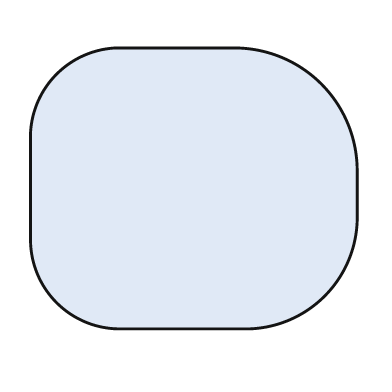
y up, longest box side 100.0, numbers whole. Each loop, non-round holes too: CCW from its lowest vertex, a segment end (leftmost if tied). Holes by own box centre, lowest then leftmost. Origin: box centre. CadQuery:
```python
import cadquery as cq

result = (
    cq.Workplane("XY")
    .moveTo(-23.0, -43.0)
    .lineTo(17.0, -43.0)
    .threePointArc((40.0, -33.0), (50.0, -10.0))
    .lineTo(50.0, 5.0)
    .threePointArc((39.0, 32.0), (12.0, 43.0))
    .lineTo(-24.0, 43.0)
    .threePointArc((-42.0, 35.0), (-50.0, 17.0))
    .lineTo(-50.0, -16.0)
    .threePointArc((-42.0, -35.0), (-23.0, -43.0))
    .close()
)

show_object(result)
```